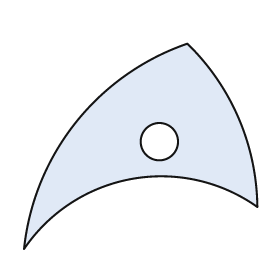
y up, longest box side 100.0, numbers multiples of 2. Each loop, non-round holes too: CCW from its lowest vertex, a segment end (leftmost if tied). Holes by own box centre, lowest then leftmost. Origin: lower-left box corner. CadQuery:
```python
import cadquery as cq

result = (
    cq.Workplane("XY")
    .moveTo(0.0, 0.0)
    .threePointArc((46.0, 30.0), (100.0, 18.0))
    .threePointArc((92.0, 56.0), (70.0, 88.0))
    .threePointArc((22.0, 54.0), (0.0, 0.0))
    .close()
    .moveTo(58.0, 46.0)
    .circle(8.0)
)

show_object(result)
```